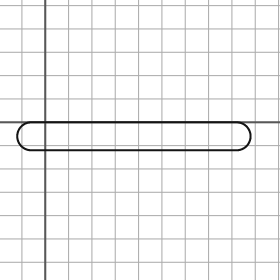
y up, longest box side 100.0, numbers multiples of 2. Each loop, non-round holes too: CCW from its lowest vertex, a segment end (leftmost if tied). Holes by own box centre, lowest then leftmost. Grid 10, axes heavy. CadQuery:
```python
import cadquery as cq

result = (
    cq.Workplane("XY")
    .moveTo(-6.0, -12.0)
    .lineTo(82.0, -12.0)
    .threePointArc((88.0, -6.0), (82.0, 0.0))
    .lineTo(-6.0, 0.0)
    .threePointArc((-12.0, -6.0), (-6.0, -12.0))
    .close()
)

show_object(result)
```